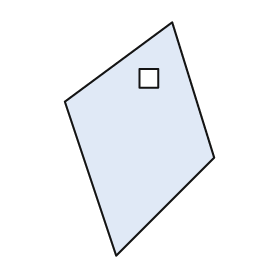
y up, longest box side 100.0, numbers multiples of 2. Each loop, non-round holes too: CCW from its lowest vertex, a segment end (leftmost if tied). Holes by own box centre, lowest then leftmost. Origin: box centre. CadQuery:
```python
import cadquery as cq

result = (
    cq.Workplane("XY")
    .moveTo(-10.0, -50.0)
    .lineTo(32.0, -8.0)
    .lineTo(14.0, 50.0)
    .lineTo(-32.0, 16.0)
    .close()
    .moveTo(0.0, 22.0)
    .lineTo(8.0, 22.0)
    .lineTo(8.0, 30.0)
    .lineTo(0.0, 30.0)
    .close()
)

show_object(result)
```